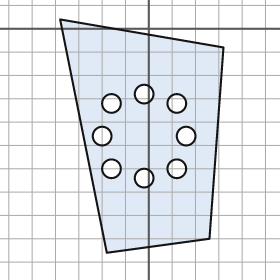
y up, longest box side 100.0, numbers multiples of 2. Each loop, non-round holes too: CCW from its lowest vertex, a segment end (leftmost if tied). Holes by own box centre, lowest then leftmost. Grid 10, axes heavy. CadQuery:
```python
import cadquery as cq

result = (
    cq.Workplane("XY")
    .moveTo(-18.0, -96.0)
    .lineTo(26.0, -90.0)
    .lineTo(32.0, -8.0)
    .lineTo(-38.0, 4.0)
    .close()
    .moveTo(-2.0, -64.0)
    .circle(4.0)
    .moveTo(-16.0, -60.0)
    .circle(4.0)
    .moveTo(12.0, -60.0)
    .circle(4.0)
    .moveTo(-20.0, -46.0)
    .circle(4.0)
    .moveTo(16.0, -46.0)
    .circle(4.0)
    .moveTo(-16.0, -32.0)
    .circle(4.0)
    .moveTo(12.0, -32.0)
    .circle(4.0)
    .moveTo(-2.0, -28.0)
    .circle(4.0)
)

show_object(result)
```